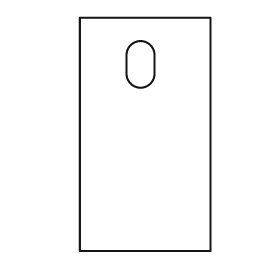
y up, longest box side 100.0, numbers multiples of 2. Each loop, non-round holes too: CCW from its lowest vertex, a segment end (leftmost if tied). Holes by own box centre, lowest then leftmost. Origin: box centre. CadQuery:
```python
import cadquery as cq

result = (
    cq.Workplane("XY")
    .moveTo(-28.0, -50.0)
    .lineTo(28.0, -50.0)
    .lineTo(28.0, 50.0)
    .lineTo(-28.0, 50.0)
    .close()
    .moveTo(-8.0, 26.0)
    .threePointArc((-2.0, 20.0), (4.0, 26.0))
    .lineTo(4.0, 34.0)
    .threePointArc((-2.0, 40.0), (-8.0, 34.0))
    .close()
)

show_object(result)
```